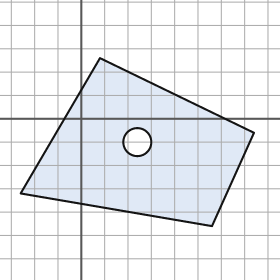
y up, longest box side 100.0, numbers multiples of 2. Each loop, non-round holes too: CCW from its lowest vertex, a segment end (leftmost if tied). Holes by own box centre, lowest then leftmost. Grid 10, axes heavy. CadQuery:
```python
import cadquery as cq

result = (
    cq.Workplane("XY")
    .moveTo(56.0, -46.0)
    .lineTo(74.0, -6.0)
    .lineTo(8.0, 26.0)
    .lineTo(-26.0, -32.0)
    .close()
    .moveTo(24.0, -10.0)
    .circle(6.0)
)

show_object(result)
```